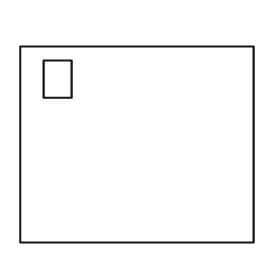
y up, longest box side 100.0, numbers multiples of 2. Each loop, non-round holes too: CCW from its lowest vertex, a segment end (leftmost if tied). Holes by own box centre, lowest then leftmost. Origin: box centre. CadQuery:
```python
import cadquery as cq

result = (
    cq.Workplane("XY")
    .moveTo(-50.0, -42.0)
    .lineTo(50.0, -42.0)
    .lineTo(50.0, 42.0)
    .lineTo(-50.0, 42.0)
    .close()
    .moveTo(-40.0, 20.0)
    .lineTo(-28.0, 20.0)
    .lineTo(-28.0, 36.0)
    .lineTo(-40.0, 36.0)
    .close()
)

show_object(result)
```